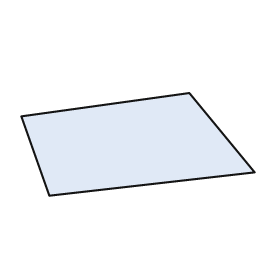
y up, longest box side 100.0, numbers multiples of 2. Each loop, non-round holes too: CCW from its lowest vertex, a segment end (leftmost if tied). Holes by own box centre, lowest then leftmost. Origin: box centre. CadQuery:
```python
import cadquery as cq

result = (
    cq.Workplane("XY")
    .moveTo(-38.0, -22.0)
    .lineTo(50.0, -12.0)
    .lineTo(22.0, 22.0)
    .lineTo(-50.0, 12.0)
    .close()
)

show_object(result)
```